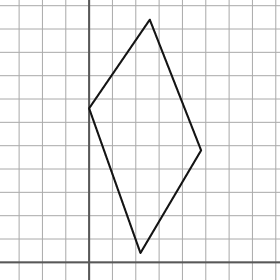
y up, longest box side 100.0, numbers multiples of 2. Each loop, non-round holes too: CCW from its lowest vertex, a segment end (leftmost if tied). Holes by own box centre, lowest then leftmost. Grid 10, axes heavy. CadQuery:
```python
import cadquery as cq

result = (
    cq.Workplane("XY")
    .moveTo(22.0, 4.0)
    .lineTo(48.0, 48.0)
    .lineTo(26.0, 104.0)
    .lineTo(0.0, 66.0)
    .close()
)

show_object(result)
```